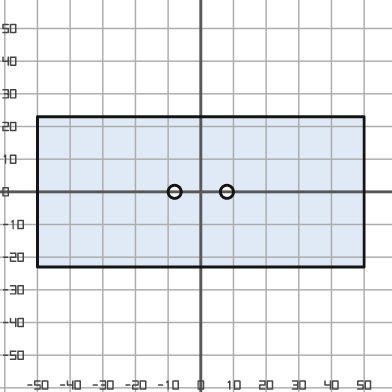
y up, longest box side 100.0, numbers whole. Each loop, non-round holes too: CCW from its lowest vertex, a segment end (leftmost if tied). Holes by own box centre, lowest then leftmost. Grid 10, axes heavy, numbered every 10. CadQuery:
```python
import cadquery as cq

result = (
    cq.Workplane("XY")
    .moveTo(-50.0, -23.0)
    .lineTo(50.0, -23.0)
    .lineTo(50.0, 23.0)
    .lineTo(-50.0, 23.0)
    .close()
    .moveTo(-8.0, 0.0)
    .circle(2.0)
    .moveTo(8.0, 0.0)
    .circle(2.0)
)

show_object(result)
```